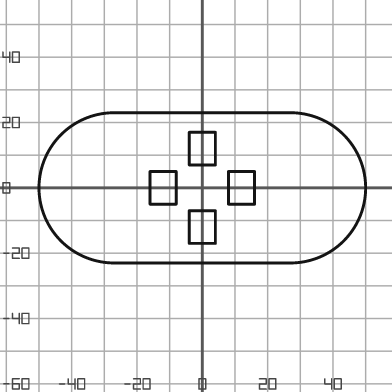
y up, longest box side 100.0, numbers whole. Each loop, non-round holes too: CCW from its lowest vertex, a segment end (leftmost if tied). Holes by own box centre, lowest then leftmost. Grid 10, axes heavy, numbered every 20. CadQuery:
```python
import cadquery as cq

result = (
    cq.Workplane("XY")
    .moveTo(-27.0, -23.0)
    .lineTo(27.0, -23.0)
    .threePointArc((50.0, 0.0), (27.0, 23.0))
    .lineTo(-27.0, 23.0)
    .threePointArc((-50.0, 0.0), (-27.0, -23.0))
    .close()
    .moveTo(-4.0, -17.0)
    .lineTo(4.0, -17.0)
    .lineTo(4.0, -7.0)
    .lineTo(-4.0, -7.0)
    .close()
    .moveTo(-16.0, -5.0)
    .lineTo(-8.0, -5.0)
    .lineTo(-8.0, 5.0)
    .lineTo(-16.0, 5.0)
    .close()
    .moveTo(8.0, -5.0)
    .lineTo(16.0, -5.0)
    .lineTo(16.0, 5.0)
    .lineTo(8.0, 5.0)
    .close()
    .moveTo(-4.0, 7.0)
    .lineTo(4.0, 7.0)
    .lineTo(4.0, 17.0)
    .lineTo(-4.0, 17.0)
    .close()
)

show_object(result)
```